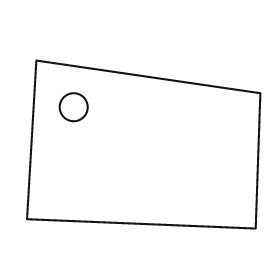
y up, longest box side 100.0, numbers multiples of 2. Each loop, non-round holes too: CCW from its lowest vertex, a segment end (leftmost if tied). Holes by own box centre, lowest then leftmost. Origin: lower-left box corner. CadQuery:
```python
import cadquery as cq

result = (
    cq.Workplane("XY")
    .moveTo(98.0, 0.0)
    .lineTo(100.0, 58.0)
    .lineTo(4.0, 72.0)
    .lineTo(0.0, 4.0)
    .close()
    .moveTo(20.0, 52.0)
    .circle(6.0)
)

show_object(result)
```